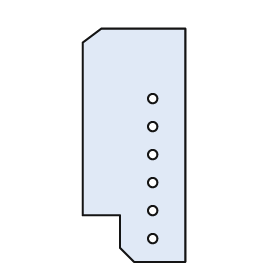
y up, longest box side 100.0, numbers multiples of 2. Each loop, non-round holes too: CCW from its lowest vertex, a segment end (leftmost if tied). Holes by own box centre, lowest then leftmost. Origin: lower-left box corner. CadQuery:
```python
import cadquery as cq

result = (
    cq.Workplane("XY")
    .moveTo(22.0, 0.0)
    .lineTo(44.0, 0.0)
    .lineTo(44.0, 100.0)
    .lineTo(8.0, 100.0)
    .lineTo(0.0, 94.0)
    .lineTo(0.0, 20.0)
    .lineTo(16.0, 20.0)
    .lineTo(16.0, 6.0)
    .close()
    .moveTo(30.0, 10.0)
    .circle(2.0)
    .moveTo(30.0, 22.0)
    .circle(2.0)
    .moveTo(30.0, 34.0)
    .circle(2.0)
    .moveTo(30.0, 46.0)
    .circle(2.0)
    .moveTo(30.0, 58.0)
    .circle(2.0)
    .moveTo(30.0, 70.0)
    .circle(2.0)
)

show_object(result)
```